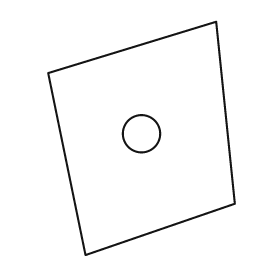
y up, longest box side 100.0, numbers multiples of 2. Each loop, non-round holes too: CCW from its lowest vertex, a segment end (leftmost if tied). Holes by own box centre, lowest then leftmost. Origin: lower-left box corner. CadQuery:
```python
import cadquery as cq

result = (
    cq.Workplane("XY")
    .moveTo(16.0, 0.0)
    .lineTo(80.0, 22.0)
    .lineTo(72.0, 100.0)
    .lineTo(0.0, 78.0)
    .close()
    .moveTo(40.0, 52.0)
    .circle(8.0)
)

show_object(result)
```